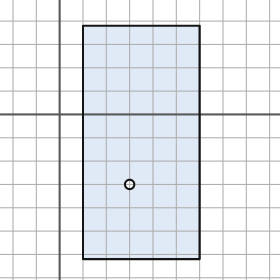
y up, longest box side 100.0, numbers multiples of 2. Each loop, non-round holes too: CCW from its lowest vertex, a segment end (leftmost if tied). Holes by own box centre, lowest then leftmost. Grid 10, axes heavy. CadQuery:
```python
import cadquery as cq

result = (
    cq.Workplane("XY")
    .moveTo(10.0, -62.0)
    .lineTo(60.0, -62.0)
    .lineTo(60.0, 38.0)
    .lineTo(10.0, 38.0)
    .close()
    .moveTo(30.0, -30.0)
    .circle(2.0)
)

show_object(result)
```